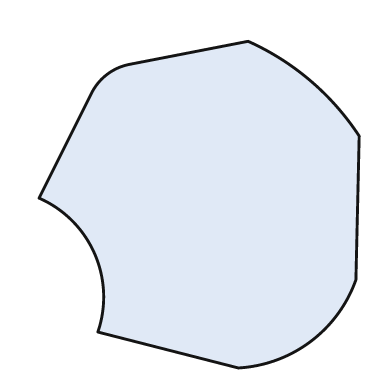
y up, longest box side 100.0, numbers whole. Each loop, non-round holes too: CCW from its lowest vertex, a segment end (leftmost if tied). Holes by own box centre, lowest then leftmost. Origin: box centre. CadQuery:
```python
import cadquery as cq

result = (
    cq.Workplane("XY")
    .moveTo(12.0, -50.0)
    .threePointArc((34.0, -42.0), (48.0, -23.0))
    .lineTo(49.0, 21.0)
    .threePointArc((34.0, 38.0), (15.0, 50.0))
    .lineTo(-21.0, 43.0)
    .threePointArc((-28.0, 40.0), (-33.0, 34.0))
    .lineTo(-49.0, 2.0)
    .threePointArc((-32.0, -15.0), (-31.0, -39.0))
    .close()
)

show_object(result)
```